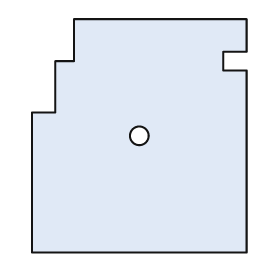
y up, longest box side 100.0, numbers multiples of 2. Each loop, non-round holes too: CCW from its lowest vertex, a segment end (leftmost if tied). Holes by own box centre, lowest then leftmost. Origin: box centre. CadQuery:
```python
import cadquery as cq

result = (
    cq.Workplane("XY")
    .moveTo(-46.0, -50.0)
    .lineTo(46.0, -50.0)
    .lineTo(46.0, 28.0)
    .lineTo(36.0, 28.0)
    .lineTo(36.0, 36.0)
    .lineTo(46.0, 36.0)
    .lineTo(46.0, 50.0)
    .lineTo(-28.0, 50.0)
    .lineTo(-28.0, 32.0)
    .lineTo(-36.0, 32.0)
    .lineTo(-36.0, 10.0)
    .lineTo(-46.0, 10.0)
    .close()
    .moveTo(0.0, 0.0)
    .circle(4.0)
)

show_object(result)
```